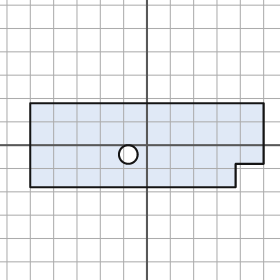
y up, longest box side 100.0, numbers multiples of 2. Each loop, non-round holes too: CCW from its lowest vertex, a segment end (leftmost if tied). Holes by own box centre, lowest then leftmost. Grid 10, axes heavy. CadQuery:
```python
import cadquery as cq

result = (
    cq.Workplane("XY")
    .moveTo(-50.0, -18.0)
    .lineTo(38.0, -18.0)
    .lineTo(38.0, -8.0)
    .lineTo(50.0, -8.0)
    .lineTo(50.0, 18.0)
    .lineTo(-50.0, 18.0)
    .close()
    .moveTo(-8.0, -4.0)
    .circle(4.0)
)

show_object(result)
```